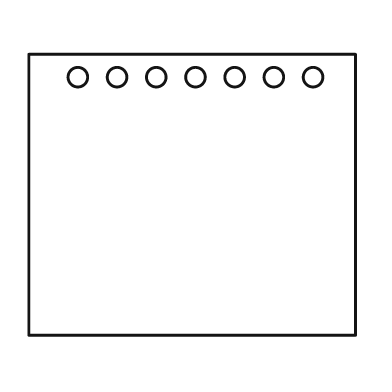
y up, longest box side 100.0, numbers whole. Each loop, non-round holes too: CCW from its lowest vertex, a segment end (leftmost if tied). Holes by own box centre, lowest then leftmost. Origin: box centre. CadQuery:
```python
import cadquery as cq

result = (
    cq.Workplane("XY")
    .moveTo(-50.0, -43.0)
    .lineTo(50.0, -43.0)
    .lineTo(50.0, 43.0)
    .lineTo(-50.0, 43.0)
    .close()
    .moveTo(-35.0, 36.0)
    .circle(3.0)
    .moveTo(-23.0, 36.0)
    .circle(3.0)
    .moveTo(-11.0, 36.0)
    .circle(3.0)
    .moveTo(1.0, 36.0)
    .circle(3.0)
    .moveTo(13.0, 36.0)
    .circle(3.0)
    .moveTo(25.0, 36.0)
    .circle(3.0)
    .moveTo(37.0, 36.0)
    .circle(3.0)
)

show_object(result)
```